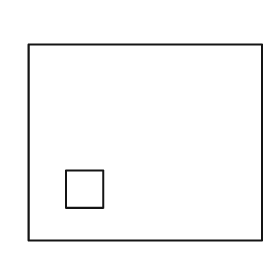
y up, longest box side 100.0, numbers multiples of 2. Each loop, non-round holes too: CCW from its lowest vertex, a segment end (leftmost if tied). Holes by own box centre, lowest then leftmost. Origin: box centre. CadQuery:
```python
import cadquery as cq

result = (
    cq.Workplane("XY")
    .moveTo(-50.0, -42.0)
    .lineTo(50.0, -42.0)
    .lineTo(50.0, 42.0)
    .lineTo(-50.0, 42.0)
    .close()
    .moveTo(-34.0, -28.0)
    .lineTo(-18.0, -28.0)
    .lineTo(-18.0, -12.0)
    .lineTo(-34.0, -12.0)
    .close()
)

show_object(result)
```